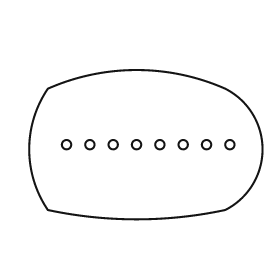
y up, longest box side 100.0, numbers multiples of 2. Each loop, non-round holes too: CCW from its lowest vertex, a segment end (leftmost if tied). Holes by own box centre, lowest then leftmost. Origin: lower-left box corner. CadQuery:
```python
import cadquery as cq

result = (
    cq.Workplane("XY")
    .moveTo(8.0, 4.0)
    .threePointArc((46.0, 0.0), (84.0, 4.0))
    .threePointArc((100.0, 30.0), (84.0, 56.0))
    .threePointArc((46.0, 64.0), (8.0, 56.0))
    .threePointArc((0.0, 30.0), (8.0, 4.0))
    .close()
    .moveTo(16.0, 32.0)
    .circle(2.0)
    .moveTo(26.0, 32.0)
    .circle(2.0)
    .moveTo(36.0, 32.0)
    .circle(2.0)
    .moveTo(46.0, 32.0)
    .circle(2.0)
    .moveTo(56.0, 32.0)
    .circle(2.0)
    .moveTo(66.0, 32.0)
    .circle(2.0)
    .moveTo(76.0, 32.0)
    .circle(2.0)
    .moveTo(86.0, 32.0)
    .circle(2.0)
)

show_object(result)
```